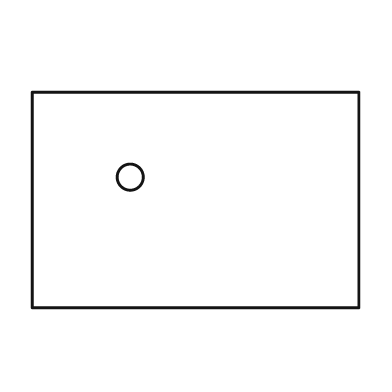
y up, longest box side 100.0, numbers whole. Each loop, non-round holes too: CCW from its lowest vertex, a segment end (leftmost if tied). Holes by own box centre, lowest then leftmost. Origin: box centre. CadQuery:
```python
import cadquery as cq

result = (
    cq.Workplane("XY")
    .moveTo(-50.0, -33.0)
    .lineTo(50.0, -33.0)
    .lineTo(50.0, 33.0)
    .lineTo(-50.0, 33.0)
    .close()
    .moveTo(-20.0, 7.0)
    .circle(4.0)
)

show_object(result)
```